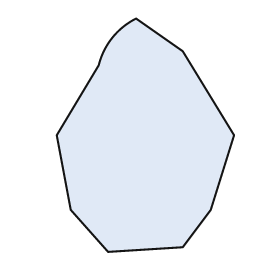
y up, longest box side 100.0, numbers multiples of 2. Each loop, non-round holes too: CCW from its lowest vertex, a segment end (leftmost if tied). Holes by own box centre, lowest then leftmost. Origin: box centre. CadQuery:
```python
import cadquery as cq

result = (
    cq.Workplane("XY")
    .moveTo(-16.0, -50.0)
    .lineTo(16.0, -48.0)
    .lineTo(28.0, -32.0)
    .lineTo(38.0, 0.0)
    .lineTo(16.0, 36.0)
    .lineTo(-4.0, 50.0)
    .threePointArc((-14.0, 42.0), (-20.0, 30.0))
    .lineTo(-38.0, 0.0)
    .lineTo(-32.0, -32.0)
    .close()
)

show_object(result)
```